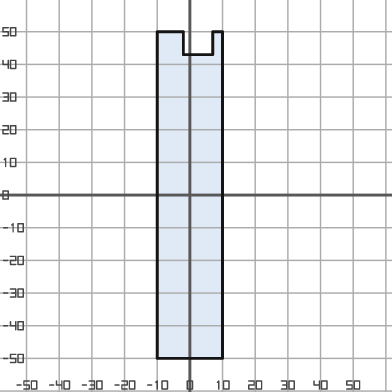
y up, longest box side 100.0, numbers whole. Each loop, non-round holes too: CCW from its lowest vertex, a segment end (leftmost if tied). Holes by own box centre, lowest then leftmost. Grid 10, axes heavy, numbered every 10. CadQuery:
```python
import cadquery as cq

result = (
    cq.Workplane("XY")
    .moveTo(-10.0, -50.0)
    .lineTo(10.0, -50.0)
    .lineTo(10.0, 50.0)
    .lineTo(7.0, 50.0)
    .lineTo(7.0, 43.0)
    .lineTo(-2.0, 43.0)
    .lineTo(-2.0, 50.0)
    .lineTo(-10.0, 50.0)
    .close()
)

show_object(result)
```